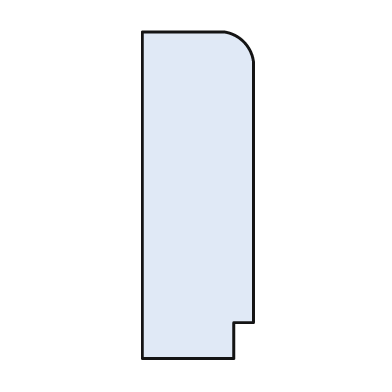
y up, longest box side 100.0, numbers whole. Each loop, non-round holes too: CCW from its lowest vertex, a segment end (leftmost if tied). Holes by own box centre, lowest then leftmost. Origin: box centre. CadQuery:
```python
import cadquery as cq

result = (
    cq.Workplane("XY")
    .moveTo(-17.0, -50.0)
    .lineTo(11.0, -50.0)
    .lineTo(11.0, -39.0)
    .lineTo(17.0, -39.0)
    .lineTo(17.0, 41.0)
    .threePointArc((14.0, 47.0), (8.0, 50.0))
    .lineTo(-17.0, 50.0)
    .close()
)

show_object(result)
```